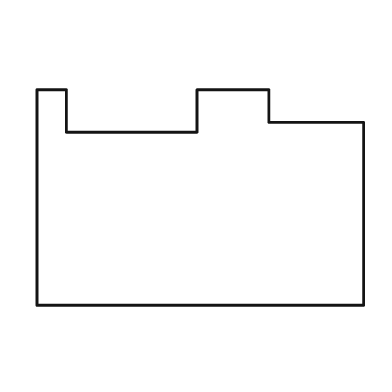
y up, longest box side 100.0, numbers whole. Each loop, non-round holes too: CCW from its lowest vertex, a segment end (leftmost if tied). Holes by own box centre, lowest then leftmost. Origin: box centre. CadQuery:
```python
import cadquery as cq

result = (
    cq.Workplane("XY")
    .moveTo(-50.0, -33.0)
    .lineTo(50.0, -33.0)
    .lineTo(50.0, 23.0)
    .lineTo(21.0, 23.0)
    .lineTo(21.0, 33.0)
    .lineTo(-1.0, 33.0)
    .lineTo(-1.0, 20.0)
    .lineTo(-41.0, 20.0)
    .lineTo(-41.0, 33.0)
    .lineTo(-50.0, 33.0)
    .close()
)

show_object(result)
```